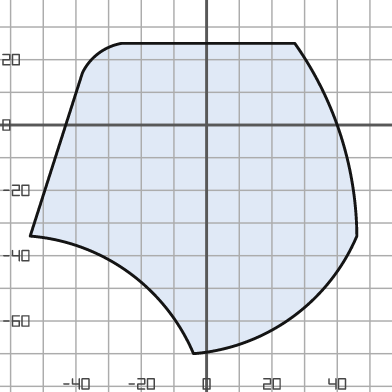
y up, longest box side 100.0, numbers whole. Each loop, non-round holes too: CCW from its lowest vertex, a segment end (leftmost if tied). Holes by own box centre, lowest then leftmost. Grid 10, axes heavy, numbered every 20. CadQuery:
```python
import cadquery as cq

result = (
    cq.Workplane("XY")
    .moveTo(-4.0, -70.0)
    .threePointArc((26.0, -59.0), (46.0, -34.0))
    .threePointArc((41.0, -3.0), (27.0, 25.0))
    .lineTo(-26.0, 25.0)
    .threePointArc((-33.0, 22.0), (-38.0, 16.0))
    .lineTo(-54.0, -34.0)
    .threePointArc((-24.0, -45.0), (-4.0, -70.0))
    .close()
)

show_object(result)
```